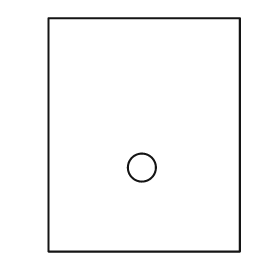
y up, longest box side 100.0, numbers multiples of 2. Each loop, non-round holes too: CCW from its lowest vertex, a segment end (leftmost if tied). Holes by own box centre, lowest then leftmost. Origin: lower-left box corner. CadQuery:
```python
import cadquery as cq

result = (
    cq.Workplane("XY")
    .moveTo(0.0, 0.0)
    .lineTo(82.0, 0.0)
    .lineTo(82.0, 100.0)
    .lineTo(0.0, 100.0)
    .close()
    .moveTo(40.0, 36.0)
    .circle(6.0)
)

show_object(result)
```